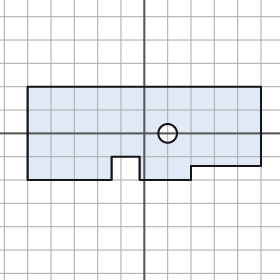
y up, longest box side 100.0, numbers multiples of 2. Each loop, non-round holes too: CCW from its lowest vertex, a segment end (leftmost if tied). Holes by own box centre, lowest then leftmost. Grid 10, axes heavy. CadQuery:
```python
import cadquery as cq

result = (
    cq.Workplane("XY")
    .moveTo(-50.0, -20.0)
    .lineTo(-14.0, -20.0)
    .lineTo(-14.0, -10.0)
    .lineTo(-2.0, -10.0)
    .lineTo(-2.0, -20.0)
    .lineTo(20.0, -20.0)
    .lineTo(20.0, -14.0)
    .lineTo(50.0, -14.0)
    .lineTo(50.0, 20.0)
    .lineTo(-50.0, 20.0)
    .close()
    .moveTo(10.0, 0.0)
    .circle(4.0)
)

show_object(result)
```